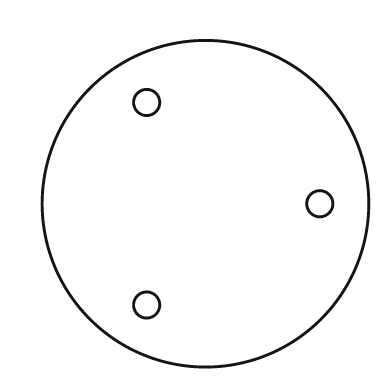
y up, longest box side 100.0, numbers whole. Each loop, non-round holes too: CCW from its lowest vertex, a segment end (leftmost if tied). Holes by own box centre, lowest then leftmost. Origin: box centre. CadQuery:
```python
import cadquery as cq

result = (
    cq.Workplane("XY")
    .moveTo(0.0, 0.0)
    .circle(50.0)
    .moveTo(-18.0, -31.0)
    .circle(4.0)
    .moveTo(35.0, 0.0)
    .circle(4.0)
    .moveTo(-18.0, 31.0)
    .circle(4.0)
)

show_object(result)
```